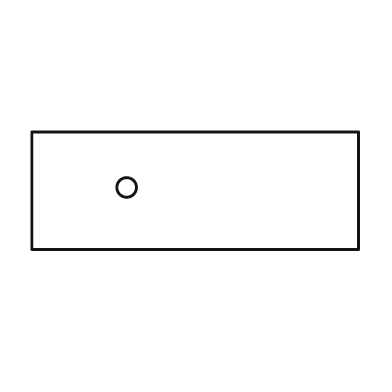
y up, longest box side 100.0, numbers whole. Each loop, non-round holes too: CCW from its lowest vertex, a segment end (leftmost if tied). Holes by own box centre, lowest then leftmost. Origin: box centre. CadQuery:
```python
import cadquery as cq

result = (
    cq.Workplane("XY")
    .moveTo(-50.0, -18.0)
    .lineTo(50.0, -18.0)
    .lineTo(50.0, 18.0)
    .lineTo(-50.0, 18.0)
    .close()
    .moveTo(-21.0, 1.0)
    .circle(3.0)
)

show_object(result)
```